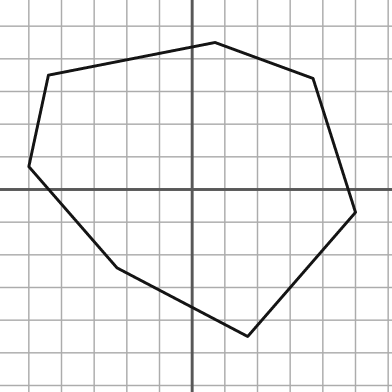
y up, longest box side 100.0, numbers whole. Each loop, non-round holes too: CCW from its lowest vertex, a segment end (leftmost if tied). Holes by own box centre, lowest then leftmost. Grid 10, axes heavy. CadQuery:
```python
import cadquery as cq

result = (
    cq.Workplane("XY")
    .moveTo(17.0, -45.0)
    .lineTo(50.0, -7.0)
    .lineTo(37.0, 34.0)
    .lineTo(7.0, 45.0)
    .lineTo(-44.0, 35.0)
    .lineTo(-50.0, 7.0)
    .lineTo(-23.0, -24.0)
    .close()
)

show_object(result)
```